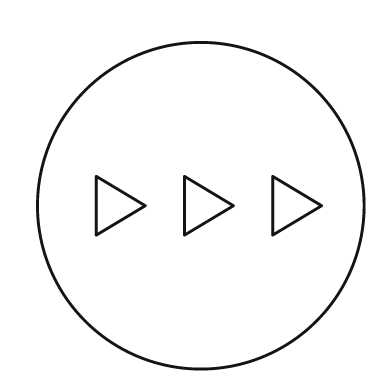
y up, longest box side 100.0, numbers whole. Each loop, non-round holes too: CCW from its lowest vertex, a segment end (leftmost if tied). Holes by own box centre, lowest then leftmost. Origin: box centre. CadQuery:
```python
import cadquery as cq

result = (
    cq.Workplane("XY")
    .moveTo(0.0, 0.0)
    .circle(50.0)
    .moveTo(-32.0, -9.0)
    .lineTo(-17.0, 0.0)
    .lineTo(-32.0, 9.0)
    .close()
    .moveTo(-5.0, -9.0)
    .lineTo(10.0, 0.0)
    .lineTo(-5.0, 9.0)
    .close()
    .moveTo(22.0, -9.0)
    .lineTo(37.0, 0.0)
    .lineTo(22.0, 9.0)
    .close()
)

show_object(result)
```